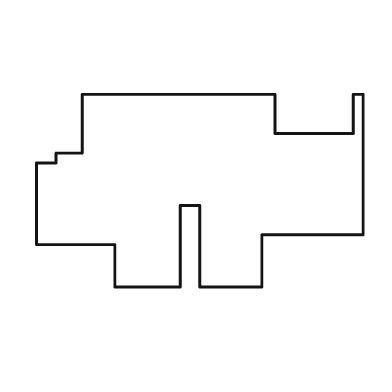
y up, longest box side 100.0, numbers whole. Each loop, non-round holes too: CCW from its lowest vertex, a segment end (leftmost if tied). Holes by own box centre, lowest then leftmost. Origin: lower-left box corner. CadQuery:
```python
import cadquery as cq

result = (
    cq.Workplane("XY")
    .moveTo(24.0, 0.0)
    .lineTo(44.0, 0.0)
    .lineTo(44.0, 25.0)
    .lineTo(50.0, 25.0)
    .lineTo(50.0, 0.0)
    .lineTo(69.0, 0.0)
    .lineTo(69.0, 16.0)
    .lineTo(100.0, 16.0)
    .lineTo(100.0, 59.0)
    .lineTo(97.0, 59.0)
    .lineTo(97.0, 47.0)
    .lineTo(73.0, 47.0)
    .lineTo(73.0, 59.0)
    .lineTo(14.0, 59.0)
    .lineTo(14.0, 41.0)
    .lineTo(6.0, 41.0)
    .lineTo(6.0, 38.0)
    .lineTo(0.0, 38.0)
    .lineTo(0.0, 13.0)
    .lineTo(24.0, 13.0)
    .close()
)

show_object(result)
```